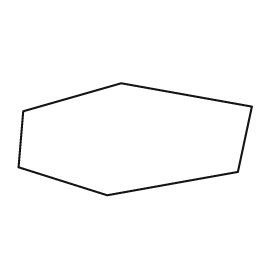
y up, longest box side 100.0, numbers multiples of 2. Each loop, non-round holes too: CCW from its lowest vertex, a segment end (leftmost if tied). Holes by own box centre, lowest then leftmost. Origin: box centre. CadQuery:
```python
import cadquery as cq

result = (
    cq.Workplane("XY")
    .moveTo(-12.0, -24.0)
    .lineTo(44.0, -14.0)
    .lineTo(50.0, 14.0)
    .lineTo(-6.0, 24.0)
    .lineTo(-48.0, 12.0)
    .lineTo(-50.0, -12.0)
    .close()
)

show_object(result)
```